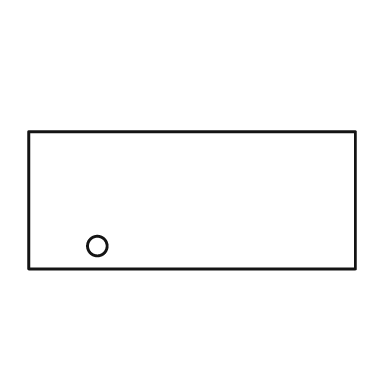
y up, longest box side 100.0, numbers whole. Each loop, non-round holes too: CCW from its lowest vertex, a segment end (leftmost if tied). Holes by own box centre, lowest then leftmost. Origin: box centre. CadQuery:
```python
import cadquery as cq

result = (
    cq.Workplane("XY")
    .moveTo(-50.0, -21.0)
    .lineTo(50.0, -21.0)
    .lineTo(50.0, 21.0)
    .lineTo(-50.0, 21.0)
    .close()
    .moveTo(-29.0, -14.0)
    .circle(3.0)
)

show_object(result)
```